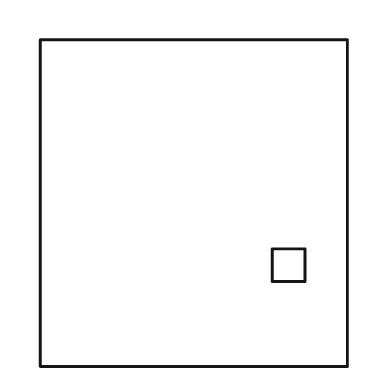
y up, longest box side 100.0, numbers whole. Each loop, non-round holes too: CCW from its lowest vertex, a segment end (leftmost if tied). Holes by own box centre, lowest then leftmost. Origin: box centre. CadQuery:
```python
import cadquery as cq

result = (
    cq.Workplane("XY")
    .moveTo(-47.0, -50.0)
    .lineTo(47.0, -50.0)
    .lineTo(47.0, 50.0)
    .lineTo(-47.0, 50.0)
    .close()
    .moveTo(24.0, -24.0)
    .lineTo(34.0, -24.0)
    .lineTo(34.0, -14.0)
    .lineTo(24.0, -14.0)
    .close()
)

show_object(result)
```